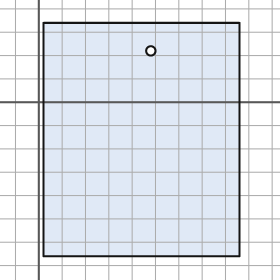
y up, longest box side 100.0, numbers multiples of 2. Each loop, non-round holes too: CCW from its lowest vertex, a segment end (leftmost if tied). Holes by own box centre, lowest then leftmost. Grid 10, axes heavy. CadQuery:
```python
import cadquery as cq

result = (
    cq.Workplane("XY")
    .moveTo(2.0, -66.0)
    .lineTo(86.0, -66.0)
    .lineTo(86.0, 34.0)
    .lineTo(2.0, 34.0)
    .close()
    .moveTo(48.0, 22.0)
    .circle(2.0)
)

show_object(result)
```